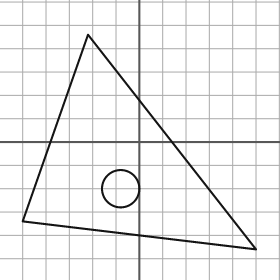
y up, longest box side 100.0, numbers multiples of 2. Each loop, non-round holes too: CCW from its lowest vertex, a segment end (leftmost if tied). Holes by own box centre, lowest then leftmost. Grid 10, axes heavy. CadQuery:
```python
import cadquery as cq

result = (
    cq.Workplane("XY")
    .moveTo(50.0, -46.0)
    .lineTo(-22.0, 46.0)
    .lineTo(-50.0, -34.0)
    .close()
    .moveTo(-8.0, -20.0)
    .circle(8.0)
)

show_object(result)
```